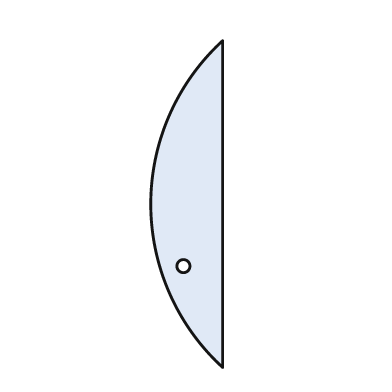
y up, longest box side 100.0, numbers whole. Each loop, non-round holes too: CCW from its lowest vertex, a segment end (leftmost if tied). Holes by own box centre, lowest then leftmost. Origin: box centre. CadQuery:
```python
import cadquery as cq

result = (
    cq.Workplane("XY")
    .moveTo(11.0, -50.0)
    .lineTo(11.0, 50.0)
    .threePointArc((-11.0, 0.0), (11.0, -50.0))
    .close()
    .moveTo(-1.0, -19.0)
    .circle(2.0)
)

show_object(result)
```